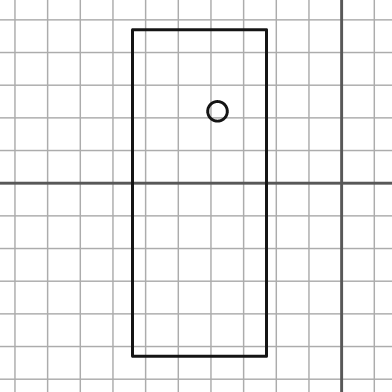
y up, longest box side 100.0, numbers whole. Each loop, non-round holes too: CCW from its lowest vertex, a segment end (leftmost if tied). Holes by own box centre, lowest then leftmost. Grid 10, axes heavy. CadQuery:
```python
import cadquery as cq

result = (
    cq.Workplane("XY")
    .moveTo(-64.0, -53.0)
    .lineTo(-23.0, -53.0)
    .lineTo(-23.0, 47.0)
    .lineTo(-64.0, 47.0)
    .close()
    .moveTo(-38.0, 22.0)
    .circle(3.0)
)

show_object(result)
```